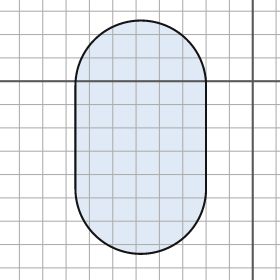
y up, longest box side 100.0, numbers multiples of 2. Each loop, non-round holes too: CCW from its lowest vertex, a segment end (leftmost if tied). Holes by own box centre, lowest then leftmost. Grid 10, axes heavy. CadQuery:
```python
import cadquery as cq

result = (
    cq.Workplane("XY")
    .moveTo(-76.0, -46.0)
    .threePointArc((-48.0, -74.0), (-20.0, -46.0))
    .lineTo(-20.0, -2.0)
    .threePointArc((-48.0, 26.0), (-76.0, -2.0))
    .close()
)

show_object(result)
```